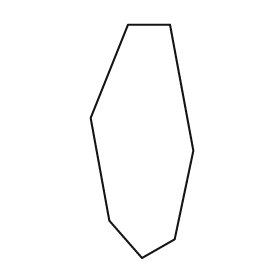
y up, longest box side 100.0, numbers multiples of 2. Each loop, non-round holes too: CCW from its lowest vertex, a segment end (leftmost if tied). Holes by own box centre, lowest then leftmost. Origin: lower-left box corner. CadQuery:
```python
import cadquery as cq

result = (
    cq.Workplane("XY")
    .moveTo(22.0, 0.0)
    .lineTo(36.0, 8.0)
    .lineTo(44.0, 46.0)
    .lineTo(34.0, 100.0)
    .lineTo(16.0, 100.0)
    .lineTo(0.0, 60.0)
    .lineTo(8.0, 16.0)
    .close()
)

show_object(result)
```